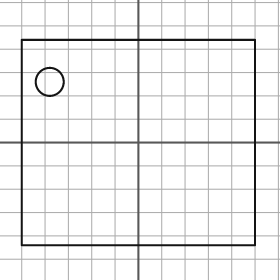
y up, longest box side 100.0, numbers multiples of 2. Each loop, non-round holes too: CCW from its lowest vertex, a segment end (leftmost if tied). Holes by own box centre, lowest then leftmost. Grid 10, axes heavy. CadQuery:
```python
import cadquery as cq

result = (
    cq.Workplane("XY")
    .moveTo(-50.0, -44.0)
    .lineTo(50.0, -44.0)
    .lineTo(50.0, 44.0)
    .lineTo(-50.0, 44.0)
    .close()
    .moveTo(-38.0, 26.0)
    .circle(6.0)
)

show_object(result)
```